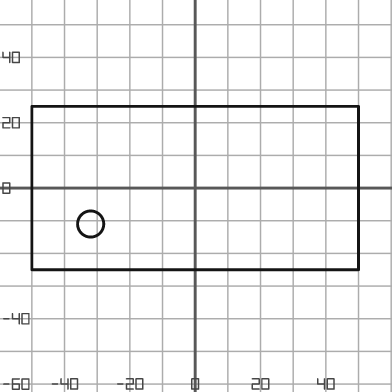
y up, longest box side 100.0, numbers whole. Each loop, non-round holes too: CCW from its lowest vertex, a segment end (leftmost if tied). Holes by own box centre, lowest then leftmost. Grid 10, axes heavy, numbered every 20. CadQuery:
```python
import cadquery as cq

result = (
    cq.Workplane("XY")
    .moveTo(-50.0, -25.0)
    .lineTo(50.0, -25.0)
    .lineTo(50.0, 25.0)
    .lineTo(-50.0, 25.0)
    .close()
    .moveTo(-32.0, -11.0)
    .circle(4.0)
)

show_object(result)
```